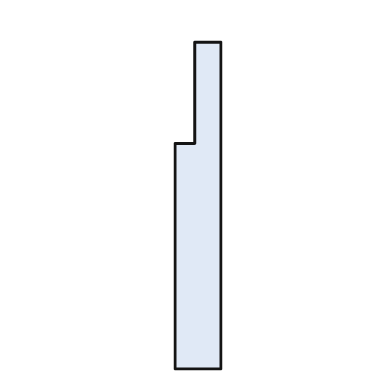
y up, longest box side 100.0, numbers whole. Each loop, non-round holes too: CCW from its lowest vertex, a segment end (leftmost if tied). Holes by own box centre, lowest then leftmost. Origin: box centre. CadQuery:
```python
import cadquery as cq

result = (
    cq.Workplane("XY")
    .moveTo(-7.0, -50.0)
    .lineTo(7.0, -50.0)
    .lineTo(7.0, 50.0)
    .lineTo(-1.0, 50.0)
    .lineTo(-1.0, 19.0)
    .lineTo(-7.0, 19.0)
    .close()
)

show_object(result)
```